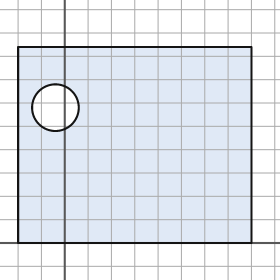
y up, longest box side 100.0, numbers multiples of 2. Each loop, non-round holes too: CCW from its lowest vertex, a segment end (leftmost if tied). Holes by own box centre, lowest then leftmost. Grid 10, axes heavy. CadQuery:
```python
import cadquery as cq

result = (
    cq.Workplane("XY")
    .moveTo(-20.0, 0.0)
    .lineTo(80.0, 0.0)
    .lineTo(80.0, 84.0)
    .lineTo(-20.0, 84.0)
    .close()
    .moveTo(-4.0, 58.0)
    .circle(10.0)
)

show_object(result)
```